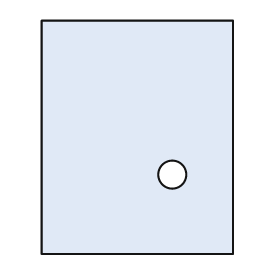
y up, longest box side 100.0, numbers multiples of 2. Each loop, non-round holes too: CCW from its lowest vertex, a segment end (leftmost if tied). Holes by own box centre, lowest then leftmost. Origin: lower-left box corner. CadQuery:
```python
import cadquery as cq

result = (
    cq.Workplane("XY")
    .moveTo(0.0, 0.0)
    .lineTo(82.0, 0.0)
    .lineTo(82.0, 100.0)
    .lineTo(0.0, 100.0)
    .close()
    .moveTo(56.0, 34.0)
    .circle(6.0)
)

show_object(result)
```